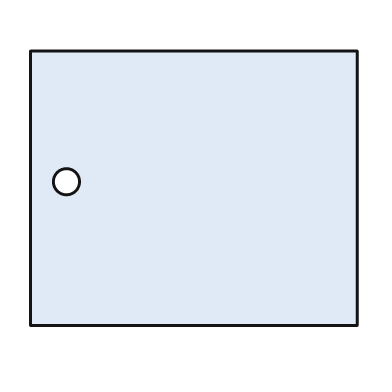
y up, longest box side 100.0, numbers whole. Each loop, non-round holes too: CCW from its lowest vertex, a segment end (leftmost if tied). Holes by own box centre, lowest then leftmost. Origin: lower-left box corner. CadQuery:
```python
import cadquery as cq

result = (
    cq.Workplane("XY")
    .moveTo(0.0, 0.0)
    .lineTo(100.0, 0.0)
    .lineTo(100.0, 84.0)
    .lineTo(0.0, 84.0)
    .close()
    .moveTo(11.0, 44.0)
    .circle(4.0)
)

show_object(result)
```